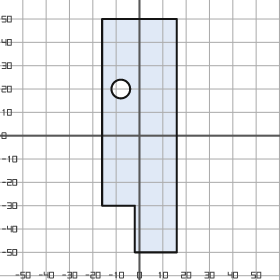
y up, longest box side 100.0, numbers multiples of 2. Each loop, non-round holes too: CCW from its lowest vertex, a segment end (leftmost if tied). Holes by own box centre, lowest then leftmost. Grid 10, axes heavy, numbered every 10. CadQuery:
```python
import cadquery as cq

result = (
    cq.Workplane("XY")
    .moveTo(-2.0, -50.0)
    .lineTo(16.0, -50.0)
    .lineTo(16.0, 50.0)
    .lineTo(-16.0, 50.0)
    .lineTo(-16.0, -30.0)
    .lineTo(-2.0, -30.0)
    .close()
    .moveTo(-8.0, 20.0)
    .circle(4.0)
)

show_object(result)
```